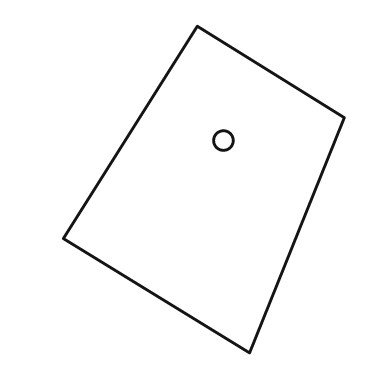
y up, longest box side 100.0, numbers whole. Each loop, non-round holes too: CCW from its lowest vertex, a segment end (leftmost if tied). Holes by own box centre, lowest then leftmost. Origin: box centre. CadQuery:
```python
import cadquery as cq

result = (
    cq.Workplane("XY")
    .moveTo(14.0, -50.0)
    .lineTo(43.0, 22.0)
    .lineTo(-2.0, 50.0)
    .lineTo(-43.0, -15.0)
    .close()
    .moveTo(6.0, 15.0)
    .circle(3.0)
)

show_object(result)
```